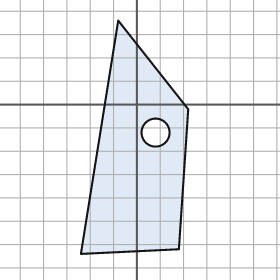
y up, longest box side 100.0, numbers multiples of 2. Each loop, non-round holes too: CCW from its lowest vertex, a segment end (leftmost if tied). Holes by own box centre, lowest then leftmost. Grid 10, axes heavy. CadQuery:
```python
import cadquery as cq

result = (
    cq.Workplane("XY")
    .moveTo(-24.0, -64.0)
    .lineTo(18.0, -62.0)
    .lineTo(22.0, -2.0)
    .lineTo(-8.0, 36.0)
    .close()
    .moveTo(8.0, -12.0)
    .circle(6.0)
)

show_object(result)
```